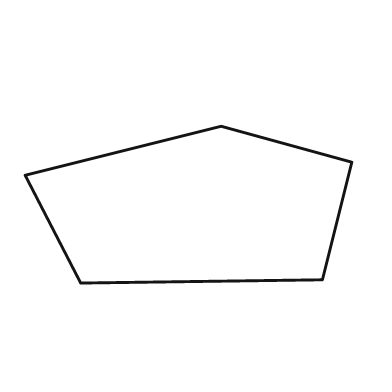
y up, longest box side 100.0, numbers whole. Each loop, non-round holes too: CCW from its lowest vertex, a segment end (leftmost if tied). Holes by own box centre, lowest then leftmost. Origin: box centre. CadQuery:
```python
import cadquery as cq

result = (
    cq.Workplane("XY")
    .moveTo(-33.0, -24.0)
    .lineTo(41.0, -23.0)
    .lineTo(50.0, 13.0)
    .lineTo(10.0, 24.0)
    .lineTo(-50.0, 9.0)
    .close()
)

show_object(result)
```